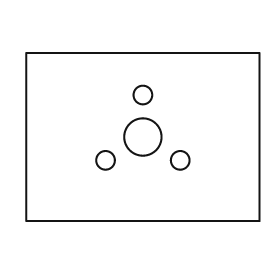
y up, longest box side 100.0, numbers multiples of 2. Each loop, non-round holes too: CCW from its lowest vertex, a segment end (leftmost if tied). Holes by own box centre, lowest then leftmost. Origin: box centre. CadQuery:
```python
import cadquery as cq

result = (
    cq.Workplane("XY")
    .moveTo(-50.0, -36.0)
    .lineTo(50.0, -36.0)
    .lineTo(50.0, 36.0)
    .lineTo(-50.0, 36.0)
    .close()
    .moveTo(-16.0, -10.0)
    .circle(4.0)
    .moveTo(16.0, -10.0)
    .circle(4.0)
    .moveTo(0.0, 0.0)
    .circle(8.0)
    .moveTo(0.0, 18.0)
    .circle(4.0)
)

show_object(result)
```